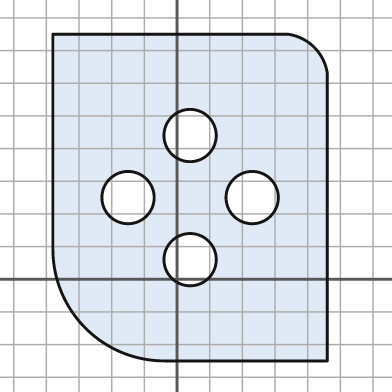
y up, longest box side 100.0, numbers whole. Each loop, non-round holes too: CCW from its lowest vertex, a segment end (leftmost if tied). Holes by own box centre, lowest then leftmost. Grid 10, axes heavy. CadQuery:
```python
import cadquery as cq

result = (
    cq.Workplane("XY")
    .moveTo(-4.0, -25.0)
    .lineTo(46.0, -25.0)
    .lineTo(46.0, 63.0)
    .threePointArc((42.0, 71.0), (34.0, 75.0))
    .lineTo(-38.0, 75.0)
    .lineTo(-38.0, 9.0)
    .threePointArc((-28.0, -15.0), (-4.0, -25.0))
    .close()
    .moveTo(4.0, 6.0)
    .circle(8.0)
    .moveTo(-15.0, 25.0)
    .circle(8.0)
    .moveTo(23.0, 25.0)
    .circle(8.0)
    .moveTo(4.0, 44.0)
    .circle(8.0)
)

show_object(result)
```